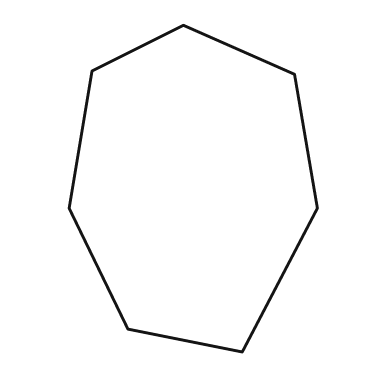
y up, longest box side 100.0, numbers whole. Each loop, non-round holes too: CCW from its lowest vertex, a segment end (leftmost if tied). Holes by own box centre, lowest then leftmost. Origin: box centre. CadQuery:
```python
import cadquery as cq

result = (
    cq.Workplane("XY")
    .moveTo(15.0, -50.0)
    .lineTo(38.0, -6.0)
    .lineTo(31.0, 35.0)
    .lineTo(-3.0, 50.0)
    .lineTo(-31.0, 36.0)
    .lineTo(-38.0, -6.0)
    .lineTo(-20.0, -43.0)
    .close()
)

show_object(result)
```